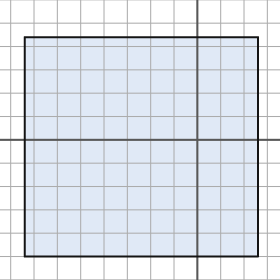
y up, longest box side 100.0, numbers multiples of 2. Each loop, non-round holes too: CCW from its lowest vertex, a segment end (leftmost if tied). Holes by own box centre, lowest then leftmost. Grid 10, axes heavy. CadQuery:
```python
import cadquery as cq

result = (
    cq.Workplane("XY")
    .moveTo(-74.0, -50.0)
    .lineTo(26.0, -50.0)
    .lineTo(26.0, 44.0)
    .lineTo(-74.0, 44.0)
    .close()
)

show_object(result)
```